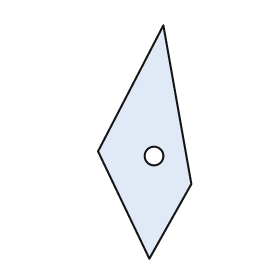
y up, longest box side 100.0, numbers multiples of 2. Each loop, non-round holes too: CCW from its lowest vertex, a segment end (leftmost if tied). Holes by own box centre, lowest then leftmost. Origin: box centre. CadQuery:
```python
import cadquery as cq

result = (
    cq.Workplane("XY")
    .moveTo(2.0, -50.0)
    .lineTo(20.0, -18.0)
    .lineTo(8.0, 50.0)
    .lineTo(-20.0, -4.0)
    .close()
    .moveTo(4.0, -6.0)
    .circle(4.0)
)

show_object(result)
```